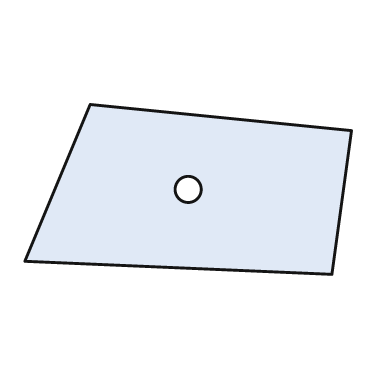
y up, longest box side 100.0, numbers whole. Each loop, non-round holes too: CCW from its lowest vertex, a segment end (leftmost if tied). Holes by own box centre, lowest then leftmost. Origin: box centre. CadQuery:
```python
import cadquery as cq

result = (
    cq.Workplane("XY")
    .moveTo(44.0, -26.0)
    .lineTo(50.0, 18.0)
    .lineTo(-30.0, 26.0)
    .lineTo(-50.0, -22.0)
    .close()
    .moveTo(0.0, 0.0)
    .circle(4.0)
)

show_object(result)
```